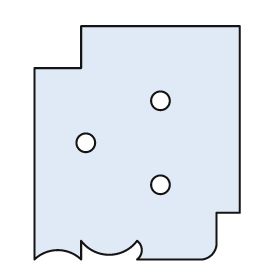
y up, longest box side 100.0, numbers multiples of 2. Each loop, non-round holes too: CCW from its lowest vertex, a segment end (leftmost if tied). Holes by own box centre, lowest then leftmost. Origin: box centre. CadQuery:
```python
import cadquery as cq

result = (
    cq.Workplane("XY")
    .moveTo(-44.0, -50.0)
    .threePointArc((-34.0, -46.0), (-24.0, -50.0))
    .lineTo(-24.0, -42.0)
    .threePointArc((-12.0, -48.0), (0.0, -42.0))
    .threePointArc((2.0, -46.0), (0.0, -50.0))
    .lineTo(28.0, -50.0)
    .threePointArc((32.0, -48.0), (34.0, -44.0))
    .lineTo(34.0, -30.0)
    .lineTo(44.0, -30.0)
    .lineTo(44.0, 50.0)
    .lineTo(-24.0, 50.0)
    .lineTo(-24.0, 32.0)
    .lineTo(-44.0, 32.0)
    .close()
    .moveTo(10.0, -18.0)
    .circle(4.0)
    .moveTo(-22.0, 0.0)
    .circle(4.0)
    .moveTo(10.0, 18.0)
    .circle(4.0)
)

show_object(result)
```